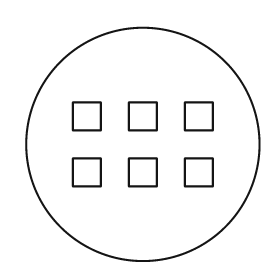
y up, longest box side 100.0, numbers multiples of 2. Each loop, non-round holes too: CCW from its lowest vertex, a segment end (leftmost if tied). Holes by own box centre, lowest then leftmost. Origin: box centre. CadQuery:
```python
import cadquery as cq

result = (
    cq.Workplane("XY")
    .moveTo(0.0, 0.0)
    .circle(50.0)
    .moveTo(-30.0, -18.0)
    .lineTo(-18.0, -18.0)
    .lineTo(-18.0, -6.0)
    .lineTo(-30.0, -6.0)
    .close()
    .moveTo(-6.0, -18.0)
    .lineTo(6.0, -18.0)
    .lineTo(6.0, -6.0)
    .lineTo(-6.0, -6.0)
    .close()
    .moveTo(18.0, -18.0)
    .lineTo(30.0, -18.0)
    .lineTo(30.0, -6.0)
    .lineTo(18.0, -6.0)
    .close()
    .moveTo(-30.0, 6.0)
    .lineTo(-18.0, 6.0)
    .lineTo(-18.0, 18.0)
    .lineTo(-30.0, 18.0)
    .close()
    .moveTo(-6.0, 6.0)
    .lineTo(6.0, 6.0)
    .lineTo(6.0, 18.0)
    .lineTo(-6.0, 18.0)
    .close()
    .moveTo(18.0, 6.0)
    .lineTo(30.0, 6.0)
    .lineTo(30.0, 18.0)
    .lineTo(18.0, 18.0)
    .close()
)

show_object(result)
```